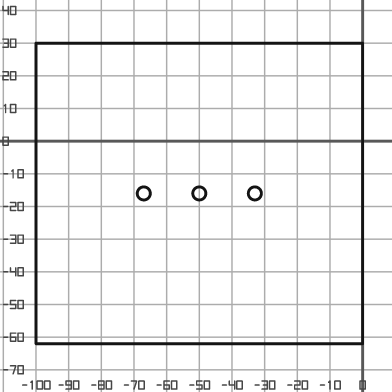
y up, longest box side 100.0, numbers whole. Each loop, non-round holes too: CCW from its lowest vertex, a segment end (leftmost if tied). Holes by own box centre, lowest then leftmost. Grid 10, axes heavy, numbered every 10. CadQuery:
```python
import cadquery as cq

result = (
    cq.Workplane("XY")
    .moveTo(-100.0, -62.0)
    .lineTo(0.0, -62.0)
    .lineTo(0.0, 30.0)
    .lineTo(-100.0, 30.0)
    .close()
    .moveTo(-67.0, -16.0)
    .circle(2.0)
    .moveTo(-50.0, -16.0)
    .circle(2.0)
    .moveTo(-33.0, -16.0)
    .circle(2.0)
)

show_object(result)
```